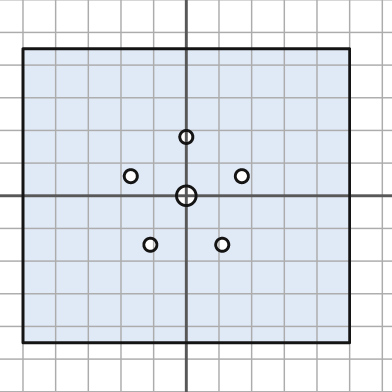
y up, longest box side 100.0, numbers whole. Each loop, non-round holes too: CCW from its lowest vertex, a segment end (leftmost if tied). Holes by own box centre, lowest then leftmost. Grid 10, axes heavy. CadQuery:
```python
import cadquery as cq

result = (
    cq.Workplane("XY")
    .moveTo(-50.0, -45.0)
    .lineTo(50.0, -45.0)
    .lineTo(50.0, 45.0)
    .lineTo(-50.0, 45.0)
    .close()
    .moveTo(-11.0, -15.0)
    .circle(2.0)
    .moveTo(11.0, -15.0)
    .circle(2.0)
    .moveTo(0.0, 0.0)
    .circle(3.0)
    .moveTo(-17.0, 6.0)
    .circle(2.0)
    .moveTo(17.0, 6.0)
    .circle(2.0)
    .moveTo(0.0, 18.0)
    .circle(2.0)
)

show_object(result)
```